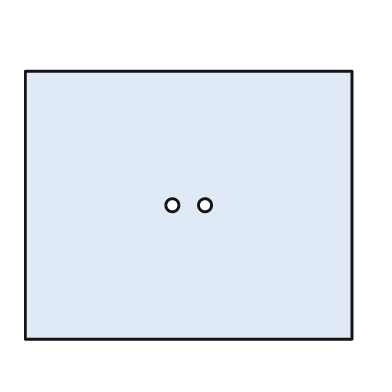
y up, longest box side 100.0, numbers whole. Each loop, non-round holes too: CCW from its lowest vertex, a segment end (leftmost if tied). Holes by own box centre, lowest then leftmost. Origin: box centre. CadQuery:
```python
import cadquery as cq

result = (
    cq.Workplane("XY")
    .moveTo(-50.0, -41.0)
    .lineTo(50.0, -41.0)
    .lineTo(50.0, 41.0)
    .lineTo(-50.0, 41.0)
    .close()
    .moveTo(-5.0, 0.0)
    .circle(2.0)
    .moveTo(5.0, 0.0)
    .circle(2.0)
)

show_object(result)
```